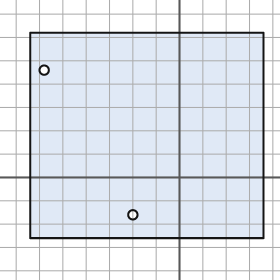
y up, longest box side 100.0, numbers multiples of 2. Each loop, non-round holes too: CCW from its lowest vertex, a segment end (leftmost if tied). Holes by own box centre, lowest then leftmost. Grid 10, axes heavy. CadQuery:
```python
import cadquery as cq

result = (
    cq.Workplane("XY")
    .moveTo(-64.0, -26.0)
    .lineTo(36.0, -26.0)
    .lineTo(36.0, 62.0)
    .lineTo(-64.0, 62.0)
    .close()
    .moveTo(-20.0, -16.0)
    .circle(2.0)
    .moveTo(-58.0, 46.0)
    .circle(2.0)
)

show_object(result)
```